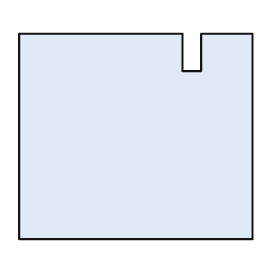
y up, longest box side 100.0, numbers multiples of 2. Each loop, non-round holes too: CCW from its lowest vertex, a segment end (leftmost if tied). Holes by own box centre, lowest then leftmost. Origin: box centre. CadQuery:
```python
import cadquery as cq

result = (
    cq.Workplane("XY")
    .moveTo(-50.0, -44.0)
    .lineTo(50.0, -44.0)
    .lineTo(50.0, 44.0)
    .lineTo(28.0, 44.0)
    .lineTo(28.0, 28.0)
    .lineTo(20.0, 28.0)
    .lineTo(20.0, 44.0)
    .lineTo(-50.0, 44.0)
    .close()
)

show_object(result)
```